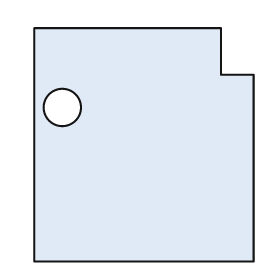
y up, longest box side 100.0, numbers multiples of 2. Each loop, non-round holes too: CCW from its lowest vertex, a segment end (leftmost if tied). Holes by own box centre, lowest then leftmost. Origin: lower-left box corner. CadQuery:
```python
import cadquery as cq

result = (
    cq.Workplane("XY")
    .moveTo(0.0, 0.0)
    .lineTo(94.0, 0.0)
    .lineTo(94.0, 80.0)
    .lineTo(80.0, 80.0)
    .lineTo(80.0, 100.0)
    .lineTo(0.0, 100.0)
    .close()
    .moveTo(12.0, 66.0)
    .circle(8.0)
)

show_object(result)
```